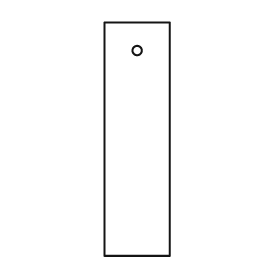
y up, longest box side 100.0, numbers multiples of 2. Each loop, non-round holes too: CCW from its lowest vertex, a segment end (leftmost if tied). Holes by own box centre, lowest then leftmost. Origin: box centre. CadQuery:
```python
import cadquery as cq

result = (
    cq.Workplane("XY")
    .moveTo(-14.0, -50.0)
    .lineTo(14.0, -50.0)
    .lineTo(14.0, 50.0)
    .lineTo(-14.0, 50.0)
    .close()
    .moveTo(0.0, 38.0)
    .circle(2.0)
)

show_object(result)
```